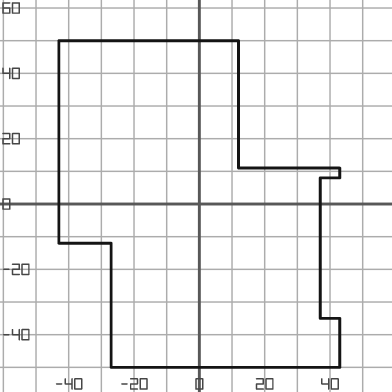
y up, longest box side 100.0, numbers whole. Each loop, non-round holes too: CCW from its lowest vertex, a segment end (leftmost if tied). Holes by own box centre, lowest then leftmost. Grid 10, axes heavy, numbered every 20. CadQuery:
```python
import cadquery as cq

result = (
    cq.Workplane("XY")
    .moveTo(-27.0, -50.0)
    .lineTo(43.0, -50.0)
    .lineTo(43.0, -35.0)
    .lineTo(37.0, -35.0)
    .lineTo(37.0, 8.0)
    .lineTo(43.0, 8.0)
    .lineTo(43.0, 11.0)
    .lineTo(12.0, 11.0)
    .lineTo(12.0, 50.0)
    .lineTo(-43.0, 50.0)
    .lineTo(-43.0, -12.0)
    .lineTo(-27.0, -12.0)
    .close()
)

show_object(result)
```